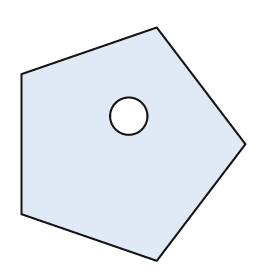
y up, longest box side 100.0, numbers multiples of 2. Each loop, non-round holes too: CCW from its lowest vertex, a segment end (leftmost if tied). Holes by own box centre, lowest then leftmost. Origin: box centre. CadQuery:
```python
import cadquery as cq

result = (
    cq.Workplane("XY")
    .moveTo(10.0, -50.0)
    .lineTo(48.0, 0.0)
    .lineTo(10.0, 50.0)
    .lineTo(-48.0, 30.0)
    .lineTo(-48.0, -30.0)
    .close()
    .moveTo(-2.0, 12.0)
    .circle(8.0)
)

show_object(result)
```